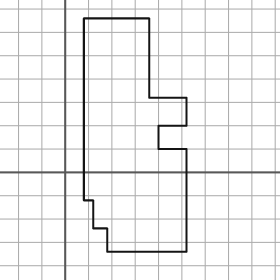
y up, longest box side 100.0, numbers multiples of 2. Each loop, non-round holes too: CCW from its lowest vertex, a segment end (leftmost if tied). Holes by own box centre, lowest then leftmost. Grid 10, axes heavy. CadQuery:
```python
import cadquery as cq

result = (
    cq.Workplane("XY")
    .moveTo(18.0, -34.0)
    .lineTo(52.0, -34.0)
    .lineTo(52.0, 10.0)
    .lineTo(40.0, 10.0)
    .lineTo(40.0, 20.0)
    .lineTo(52.0, 20.0)
    .lineTo(52.0, 32.0)
    .lineTo(36.0, 32.0)
    .lineTo(36.0, 66.0)
    .lineTo(8.0, 66.0)
    .lineTo(8.0, -12.0)
    .lineTo(12.0, -12.0)
    .lineTo(12.0, -24.0)
    .lineTo(18.0, -24.0)
    .close()
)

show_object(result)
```